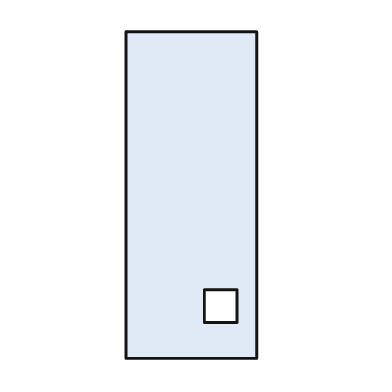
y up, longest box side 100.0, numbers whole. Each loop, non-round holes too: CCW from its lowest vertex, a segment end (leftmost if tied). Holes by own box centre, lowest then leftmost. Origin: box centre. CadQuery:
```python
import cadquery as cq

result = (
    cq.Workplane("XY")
    .moveTo(-20.0, -50.0)
    .lineTo(20.0, -50.0)
    .lineTo(20.0, 50.0)
    .lineTo(-20.0, 50.0)
    .close()
    .moveTo(4.0, -39.0)
    .lineTo(14.0, -39.0)
    .lineTo(14.0, -29.0)
    .lineTo(4.0, -29.0)
    .close()
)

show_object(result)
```